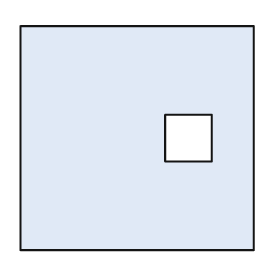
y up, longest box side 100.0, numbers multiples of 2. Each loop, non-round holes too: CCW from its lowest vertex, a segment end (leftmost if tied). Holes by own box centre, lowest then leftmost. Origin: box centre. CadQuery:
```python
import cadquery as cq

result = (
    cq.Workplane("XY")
    .moveTo(-50.0, -48.0)
    .lineTo(50.0, -48.0)
    .lineTo(50.0, 48.0)
    .lineTo(-50.0, 48.0)
    .close()
    .moveTo(12.0, -10.0)
    .lineTo(32.0, -10.0)
    .lineTo(32.0, 10.0)
    .lineTo(12.0, 10.0)
    .close()
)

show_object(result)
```